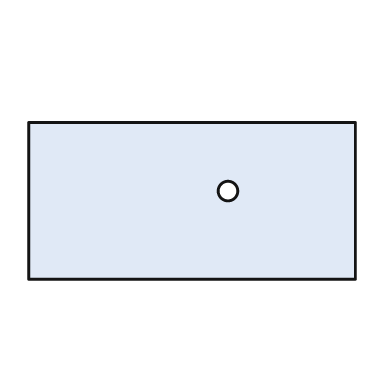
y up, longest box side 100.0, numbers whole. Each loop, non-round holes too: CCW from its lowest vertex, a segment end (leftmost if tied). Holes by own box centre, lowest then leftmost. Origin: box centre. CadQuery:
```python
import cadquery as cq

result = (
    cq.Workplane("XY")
    .moveTo(-50.0, -24.0)
    .lineTo(50.0, -24.0)
    .lineTo(50.0, 24.0)
    .lineTo(-50.0, 24.0)
    .close()
    .moveTo(11.0, 3.0)
    .circle(3.0)
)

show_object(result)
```